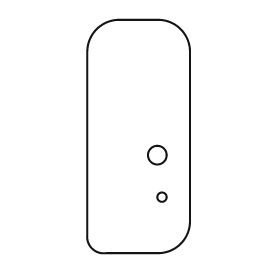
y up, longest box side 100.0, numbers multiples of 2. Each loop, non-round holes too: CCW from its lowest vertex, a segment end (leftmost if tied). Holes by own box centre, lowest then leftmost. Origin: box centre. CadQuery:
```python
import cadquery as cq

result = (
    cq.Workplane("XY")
    .moveTo(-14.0, -50.0)
    .lineTo(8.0, -50.0)
    .threePointArc((18.0, -46.0), (22.0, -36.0))
    .lineTo(22.0, 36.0)
    .threePointArc((18.0, 46.0), (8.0, 50.0))
    .lineTo(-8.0, 50.0)
    .threePointArc((-18.0, 46.0), (-22.0, 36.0))
    .lineTo(-22.0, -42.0)
    .threePointArc((-20.0, -48.0), (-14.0, -50.0))
    .close()
    .moveTo(10.0, -26.0)
    .circle(2.0)
    .moveTo(8.0, -8.0)
    .circle(4.0)
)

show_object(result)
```